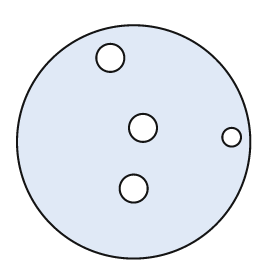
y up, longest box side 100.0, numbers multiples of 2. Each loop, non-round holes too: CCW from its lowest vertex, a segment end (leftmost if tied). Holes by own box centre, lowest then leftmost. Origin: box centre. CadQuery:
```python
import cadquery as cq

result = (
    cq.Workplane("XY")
    .moveTo(0.0, 0.0)
    .circle(50.0)
    .moveTo(0.0, -20.0)
    .circle(6.0)
    .moveTo(42.0, 2.0)
    .circle(4.0)
    .moveTo(4.0, 6.0)
    .circle(6.0)
    .moveTo(-10.0, 36.0)
    .circle(6.0)
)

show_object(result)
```